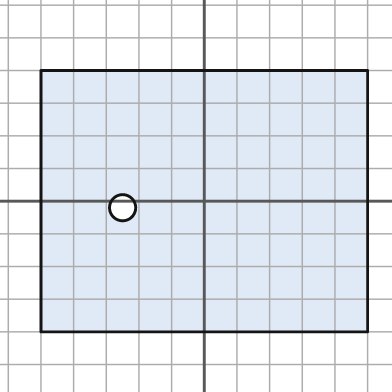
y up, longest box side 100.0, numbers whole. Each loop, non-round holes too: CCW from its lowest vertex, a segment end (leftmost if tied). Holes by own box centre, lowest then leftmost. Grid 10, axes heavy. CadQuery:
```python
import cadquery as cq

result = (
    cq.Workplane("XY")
    .moveTo(-50.0, -40.0)
    .lineTo(50.0, -40.0)
    .lineTo(50.0, 40.0)
    .lineTo(-50.0, 40.0)
    .close()
    .moveTo(-25.0, -2.0)
    .circle(4.0)
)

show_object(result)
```